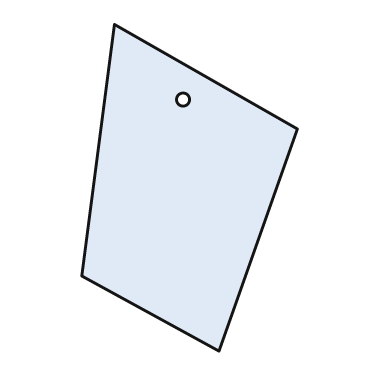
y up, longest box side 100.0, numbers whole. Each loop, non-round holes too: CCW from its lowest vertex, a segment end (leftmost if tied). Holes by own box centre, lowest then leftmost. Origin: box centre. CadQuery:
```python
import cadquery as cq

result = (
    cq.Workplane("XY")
    .moveTo(9.0, -50.0)
    .lineTo(33.0, 18.0)
    .lineTo(-23.0, 50.0)
    .lineTo(-33.0, -27.0)
    .close()
    .moveTo(-2.0, 27.0)
    .circle(2.0)
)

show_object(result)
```